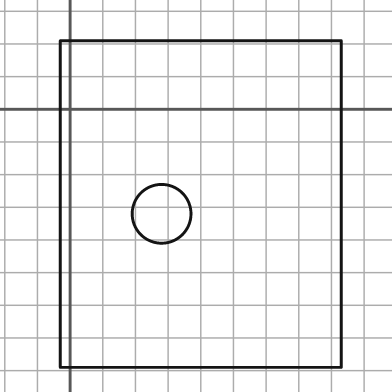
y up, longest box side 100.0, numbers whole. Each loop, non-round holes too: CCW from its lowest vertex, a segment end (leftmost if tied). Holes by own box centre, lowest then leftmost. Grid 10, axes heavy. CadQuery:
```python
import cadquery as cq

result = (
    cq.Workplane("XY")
    .moveTo(-3.0, -79.0)
    .lineTo(83.0, -79.0)
    .lineTo(83.0, 21.0)
    .lineTo(-3.0, 21.0)
    .close()
    .moveTo(28.0, -32.0)
    .circle(9.0)
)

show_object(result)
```